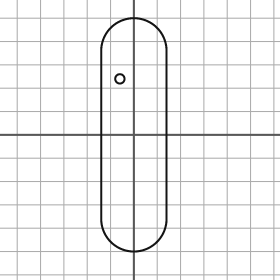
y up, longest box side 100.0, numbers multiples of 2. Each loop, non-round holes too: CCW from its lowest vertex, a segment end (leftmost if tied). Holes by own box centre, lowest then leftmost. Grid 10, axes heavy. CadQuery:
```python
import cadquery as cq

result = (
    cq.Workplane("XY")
    .moveTo(-14.0, -36.0)
    .threePointArc((0.0, -50.0), (14.0, -36.0))
    .lineTo(14.0, 36.0)
    .threePointArc((0.0, 50.0), (-14.0, 36.0))
    .close()
    .moveTo(-6.0, 24.0)
    .circle(2.0)
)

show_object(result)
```